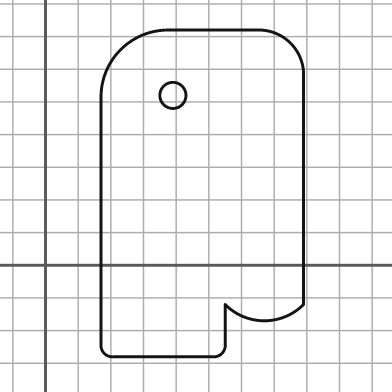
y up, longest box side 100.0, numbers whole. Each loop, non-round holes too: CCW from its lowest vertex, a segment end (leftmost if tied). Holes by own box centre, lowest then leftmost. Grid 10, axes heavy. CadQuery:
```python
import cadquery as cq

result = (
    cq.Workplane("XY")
    .moveTo(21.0, -28.0)
    .lineTo(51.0, -28.0)
    .threePointArc((54.0, -27.0), (55.0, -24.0))
    .lineTo(55.0, -12.0)
    .threePointArc((67.0, -17.0), (79.0, -12.0))
    .lineTo(79.0, 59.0)
    .threePointArc((75.0, 68.0), (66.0, 72.0))
    .lineTo(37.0, 72.0)
    .threePointArc((23.0, 66.0), (17.0, 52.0))
    .lineTo(17.0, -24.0)
    .threePointArc((18.0, -27.0), (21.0, -28.0))
    .close()
    .moveTo(39.0, 52.0)
    .circle(4.0)
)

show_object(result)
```